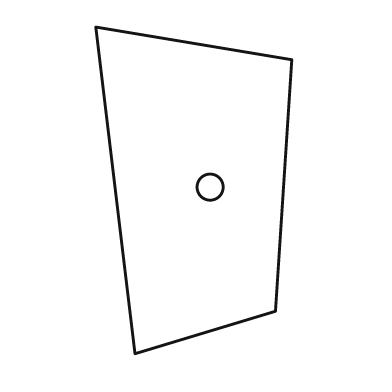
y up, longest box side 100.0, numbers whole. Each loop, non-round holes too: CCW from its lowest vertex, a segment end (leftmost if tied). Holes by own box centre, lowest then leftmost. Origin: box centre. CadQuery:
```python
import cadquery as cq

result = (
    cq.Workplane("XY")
    .moveTo(-18.0, -50.0)
    .lineTo(25.0, -37.0)
    .lineTo(30.0, 40.0)
    .lineTo(-30.0, 50.0)
    .close()
    .moveTo(5.0, 1.0)
    .circle(4.0)
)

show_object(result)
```